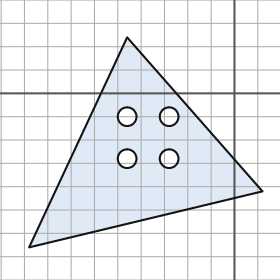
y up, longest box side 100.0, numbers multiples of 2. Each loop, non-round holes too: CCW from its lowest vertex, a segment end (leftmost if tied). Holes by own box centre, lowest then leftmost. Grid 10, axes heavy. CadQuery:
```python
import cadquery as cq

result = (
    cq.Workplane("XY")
    .moveTo(-88.0, -66.0)
    .lineTo(12.0, -42.0)
    .lineTo(-46.0, 24.0)
    .close()
    .moveTo(-46.0, -28.0)
    .circle(4.0)
    .moveTo(-28.0, -28.0)
    .circle(4.0)
    .moveTo(-46.0, -10.0)
    .circle(4.0)
    .moveTo(-28.0, -10.0)
    .circle(4.0)
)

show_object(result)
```